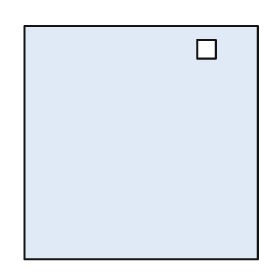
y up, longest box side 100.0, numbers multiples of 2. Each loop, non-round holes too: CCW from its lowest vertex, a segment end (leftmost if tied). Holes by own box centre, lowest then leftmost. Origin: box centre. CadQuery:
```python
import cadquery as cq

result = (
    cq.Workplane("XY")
    .moveTo(-50.0, -50.0)
    .lineTo(50.0, -50.0)
    .lineTo(50.0, 50.0)
    .lineTo(-50.0, 50.0)
    .close()
    .moveTo(24.0, 36.0)
    .lineTo(32.0, 36.0)
    .lineTo(32.0, 44.0)
    .lineTo(24.0, 44.0)
    .close()
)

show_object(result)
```